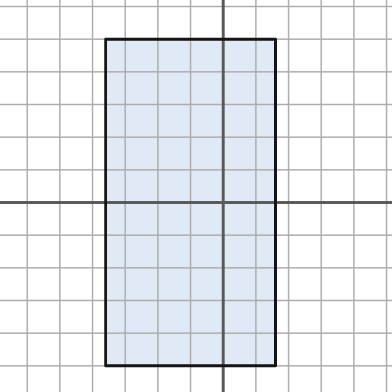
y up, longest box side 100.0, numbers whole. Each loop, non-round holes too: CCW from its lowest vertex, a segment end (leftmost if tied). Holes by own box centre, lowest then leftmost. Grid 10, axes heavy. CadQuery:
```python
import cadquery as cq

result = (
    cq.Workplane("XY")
    .moveTo(-36.0, -50.0)
    .lineTo(16.0, -50.0)
    .lineTo(16.0, 50.0)
    .lineTo(-36.0, 50.0)
    .close()
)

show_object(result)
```